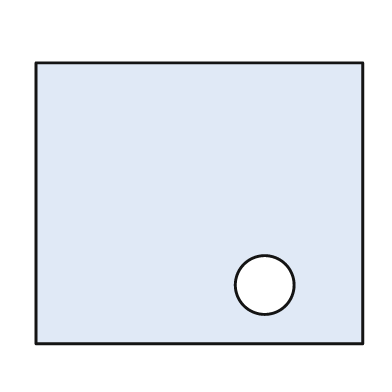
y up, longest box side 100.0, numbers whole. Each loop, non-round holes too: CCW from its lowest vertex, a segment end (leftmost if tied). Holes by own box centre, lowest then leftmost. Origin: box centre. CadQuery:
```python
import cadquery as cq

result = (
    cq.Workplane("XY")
    .moveTo(-50.0, -43.0)
    .lineTo(50.0, -43.0)
    .lineTo(50.0, 43.0)
    .lineTo(-50.0, 43.0)
    .close()
    .moveTo(20.0, -25.0)
    .circle(9.0)
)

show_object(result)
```